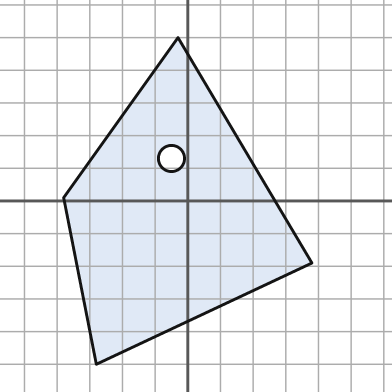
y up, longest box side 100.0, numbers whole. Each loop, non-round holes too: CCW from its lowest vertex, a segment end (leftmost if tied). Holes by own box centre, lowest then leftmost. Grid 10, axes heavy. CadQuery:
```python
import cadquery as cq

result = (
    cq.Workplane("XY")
    .moveTo(-28.0, -50.0)
    .lineTo(38.0, -19.0)
    .lineTo(-3.0, 50.0)
    .lineTo(-38.0, 1.0)
    .close()
    .moveTo(-5.0, 13.0)
    .circle(4.0)
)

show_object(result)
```